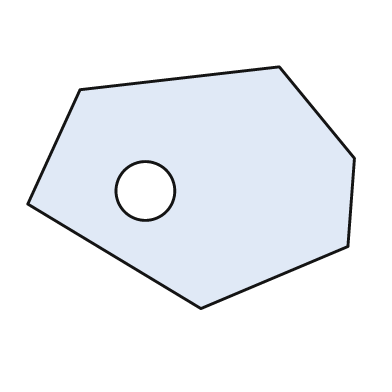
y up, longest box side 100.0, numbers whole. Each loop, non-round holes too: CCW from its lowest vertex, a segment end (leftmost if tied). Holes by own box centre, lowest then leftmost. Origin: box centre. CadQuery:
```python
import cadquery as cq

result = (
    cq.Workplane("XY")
    .moveTo(3.0, -37.0)
    .lineTo(48.0, -18.0)
    .lineTo(50.0, 9.0)
    .lineTo(27.0, 37.0)
    .lineTo(-34.0, 30.0)
    .lineTo(-50.0, -5.0)
    .close()
    .moveTo(-14.0, -1.0)
    .circle(9.0)
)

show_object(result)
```